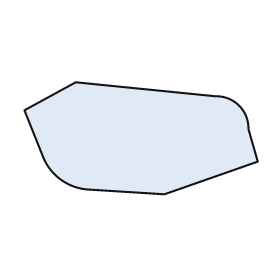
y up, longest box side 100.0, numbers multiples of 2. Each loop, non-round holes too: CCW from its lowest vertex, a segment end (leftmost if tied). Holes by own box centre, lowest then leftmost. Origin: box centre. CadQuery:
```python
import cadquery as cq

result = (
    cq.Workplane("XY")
    .moveTo(10.0, -24.0)
    .lineTo(50.0, -10.0)
    .lineTo(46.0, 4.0)
    .threePointArc((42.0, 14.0), (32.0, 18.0))
    .lineTo(-28.0, 24.0)
    .lineTo(-50.0, 12.0)
    .lineTo(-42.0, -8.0)
    .threePointArc((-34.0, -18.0), (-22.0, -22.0))
    .close()
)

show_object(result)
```